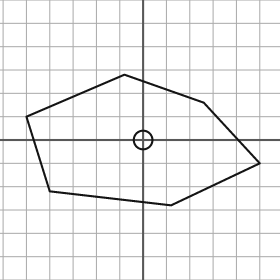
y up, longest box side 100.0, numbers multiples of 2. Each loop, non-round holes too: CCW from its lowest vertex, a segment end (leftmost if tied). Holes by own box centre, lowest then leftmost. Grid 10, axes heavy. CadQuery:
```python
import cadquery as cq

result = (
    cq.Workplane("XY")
    .moveTo(12.0, -28.0)
    .lineTo(50.0, -10.0)
    .lineTo(26.0, 16.0)
    .lineTo(-8.0, 28.0)
    .lineTo(-50.0, 10.0)
    .lineTo(-40.0, -22.0)
    .close()
    .moveTo(0.0, 0.0)
    .circle(4.0)
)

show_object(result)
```